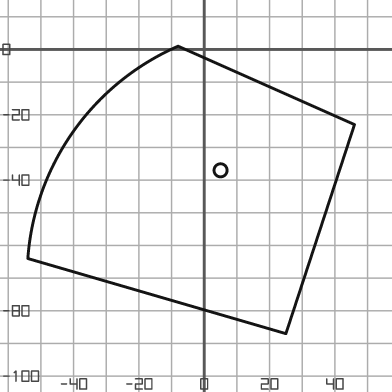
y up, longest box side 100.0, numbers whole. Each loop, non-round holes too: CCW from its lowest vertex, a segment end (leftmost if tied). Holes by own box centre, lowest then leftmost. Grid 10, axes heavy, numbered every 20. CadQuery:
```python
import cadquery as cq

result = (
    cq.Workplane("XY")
    .moveTo(25.0, -87.0)
    .lineTo(46.0, -23.0)
    .lineTo(-8.0, 1.0)
    .threePointArc((-40.0, -25.0), (-54.0, -64.0))
    .close()
    .moveTo(5.0, -37.0)
    .circle(2.0)
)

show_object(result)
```